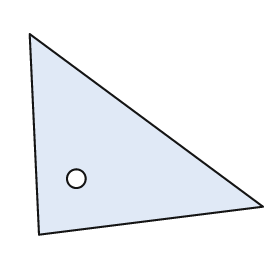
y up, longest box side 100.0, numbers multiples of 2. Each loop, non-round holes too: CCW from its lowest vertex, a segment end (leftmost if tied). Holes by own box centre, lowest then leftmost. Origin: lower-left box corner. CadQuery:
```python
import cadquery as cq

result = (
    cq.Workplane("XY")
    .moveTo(4.0, 0.0)
    .lineTo(100.0, 12.0)
    .lineTo(0.0, 86.0)
    .close()
    .moveTo(20.0, 24.0)
    .circle(4.0)
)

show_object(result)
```